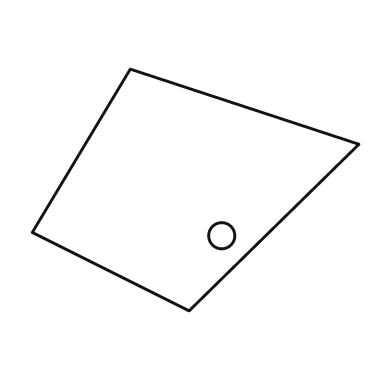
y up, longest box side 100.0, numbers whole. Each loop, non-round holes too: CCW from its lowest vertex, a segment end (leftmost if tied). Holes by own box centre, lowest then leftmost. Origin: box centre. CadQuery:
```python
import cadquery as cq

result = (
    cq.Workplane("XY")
    .moveTo(-2.0, -37.0)
    .lineTo(50.0, 14.0)
    .lineTo(-20.0, 37.0)
    .lineTo(-50.0, -13.0)
    .close()
    .moveTo(8.0, -14.0)
    .circle(4.0)
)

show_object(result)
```